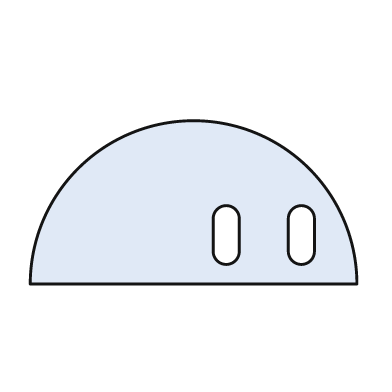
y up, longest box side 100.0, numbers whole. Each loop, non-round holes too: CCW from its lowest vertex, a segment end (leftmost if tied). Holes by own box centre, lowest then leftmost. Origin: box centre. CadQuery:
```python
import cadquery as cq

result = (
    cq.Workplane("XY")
    .moveTo(-50.0, -25.0)
    .lineTo(50.0, -25.0)
    .threePointArc((0.0, 25.0), (-50.0, -25.0))
    .close()
    .moveTo(6.0, -15.0)
    .threePointArc((10.0, -19.0), (14.0, -15.0))
    .lineTo(14.0, -5.0)
    .threePointArc((10.0, -1.0), (6.0, -5.0))
    .close()
    .moveTo(29.0, -15.0)
    .threePointArc((33.0, -19.0), (37.0, -15.0))
    .lineTo(37.0, -5.0)
    .threePointArc((33.0, -1.0), (29.0, -5.0))
    .close()
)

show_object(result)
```